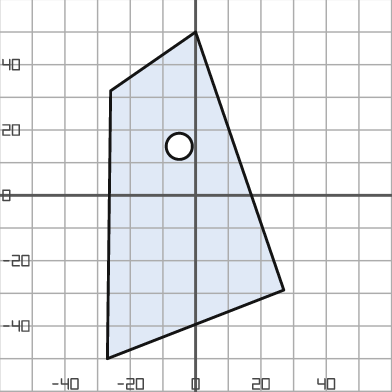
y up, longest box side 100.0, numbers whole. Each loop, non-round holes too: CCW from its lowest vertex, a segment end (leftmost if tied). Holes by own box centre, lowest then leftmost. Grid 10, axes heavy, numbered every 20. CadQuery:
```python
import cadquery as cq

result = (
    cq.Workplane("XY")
    .moveTo(-27.0, -50.0)
    .lineTo(27.0, -29.0)
    .lineTo(0.0, 50.0)
    .lineTo(-26.0, 32.0)
    .close()
    .moveTo(-5.0, 15.0)
    .circle(4.0)
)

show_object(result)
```